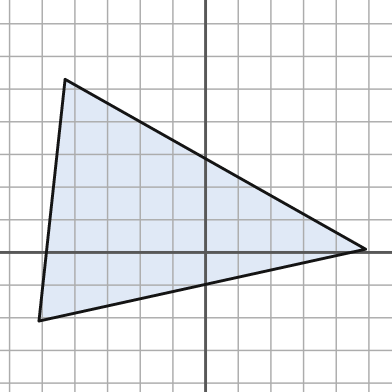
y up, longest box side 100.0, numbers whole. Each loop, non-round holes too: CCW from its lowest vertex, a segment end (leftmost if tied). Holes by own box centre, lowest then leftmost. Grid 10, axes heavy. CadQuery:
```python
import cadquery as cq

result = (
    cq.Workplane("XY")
    .moveTo(-51.0, -21.0)
    .lineTo(49.0, 1.0)
    .lineTo(-43.0, 53.0)
    .close()
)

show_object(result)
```